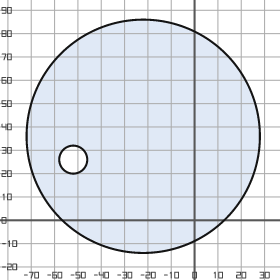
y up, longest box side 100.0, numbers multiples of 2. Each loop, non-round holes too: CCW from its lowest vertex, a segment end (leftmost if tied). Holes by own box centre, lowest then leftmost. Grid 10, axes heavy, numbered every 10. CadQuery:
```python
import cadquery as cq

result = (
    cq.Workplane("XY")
    .moveTo(-22.0, 36.0)
    .circle(50.0)
    .moveTo(-52.0, 26.0)
    .circle(6.0)
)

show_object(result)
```